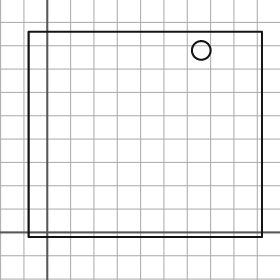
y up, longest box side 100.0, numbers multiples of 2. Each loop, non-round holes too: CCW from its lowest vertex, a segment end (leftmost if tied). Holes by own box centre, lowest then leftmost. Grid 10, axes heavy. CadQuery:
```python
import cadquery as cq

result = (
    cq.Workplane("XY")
    .moveTo(-8.0, -2.0)
    .lineTo(92.0, -2.0)
    .lineTo(92.0, 86.0)
    .lineTo(-8.0, 86.0)
    .close()
    .moveTo(66.0, 78.0)
    .circle(4.0)
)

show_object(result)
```